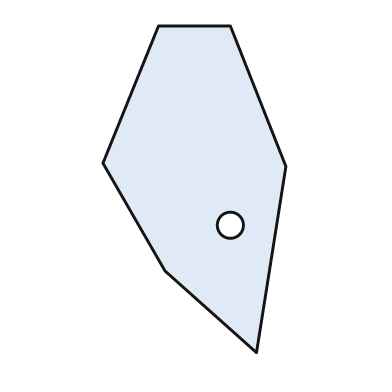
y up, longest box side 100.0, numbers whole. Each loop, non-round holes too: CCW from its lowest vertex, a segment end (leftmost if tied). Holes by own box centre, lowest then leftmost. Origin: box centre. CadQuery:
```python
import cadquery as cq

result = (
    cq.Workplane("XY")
    .moveTo(19.0, -50.0)
    .lineTo(28.0, 7.0)
    .lineTo(11.0, 50.0)
    .lineTo(-11.0, 50.0)
    .lineTo(-28.0, 8.0)
    .lineTo(-9.0, -25.0)
    .close()
    .moveTo(11.0, -11.0)
    .circle(4.0)
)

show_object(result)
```